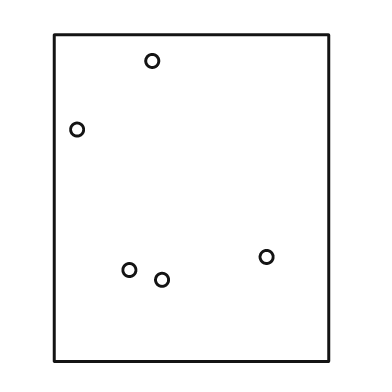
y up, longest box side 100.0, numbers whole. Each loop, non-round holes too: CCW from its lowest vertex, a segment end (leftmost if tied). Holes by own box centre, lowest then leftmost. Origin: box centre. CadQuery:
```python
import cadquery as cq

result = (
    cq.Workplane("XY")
    .moveTo(-42.0, -50.0)
    .lineTo(42.0, -50.0)
    .lineTo(42.0, 50.0)
    .lineTo(-42.0, 50.0)
    .close()
    .moveTo(-9.0, -25.0)
    .circle(2.0)
    .moveTo(-19.0, -22.0)
    .circle(2.0)
    .moveTo(23.0, -18.0)
    .circle(2.0)
    .moveTo(-35.0, 21.0)
    .circle(2.0)
    .moveTo(-12.0, 42.0)
    .circle(2.0)
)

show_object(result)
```